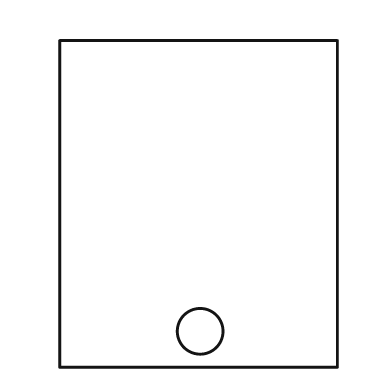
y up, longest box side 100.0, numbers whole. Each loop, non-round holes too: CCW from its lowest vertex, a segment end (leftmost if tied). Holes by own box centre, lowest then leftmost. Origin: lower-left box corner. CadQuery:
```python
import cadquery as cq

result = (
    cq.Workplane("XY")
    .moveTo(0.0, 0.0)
    .lineTo(85.0, 0.0)
    .lineTo(85.0, 100.0)
    .lineTo(0.0, 100.0)
    .close()
    .moveTo(43.0, 11.0)
    .circle(7.0)
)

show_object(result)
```